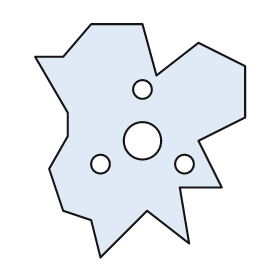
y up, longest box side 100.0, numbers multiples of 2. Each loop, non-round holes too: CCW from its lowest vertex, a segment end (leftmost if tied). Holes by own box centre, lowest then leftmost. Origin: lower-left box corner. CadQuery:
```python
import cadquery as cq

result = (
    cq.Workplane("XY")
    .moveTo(28.0, 0.0)
    .lineTo(48.0, 20.0)
    .lineTo(66.0, 6.0)
    .lineTo(62.0, 30.0)
    .lineTo(80.0, 30.0)
    .lineTo(70.0, 50.0)
    .lineTo(90.0, 60.0)
    .lineTo(90.0, 82.0)
    .lineTo(70.0, 92.0)
    .lineTo(52.0, 78.0)
    .lineTo(46.0, 100.0)
    .lineTo(24.0, 100.0)
    .lineTo(12.0, 86.0)
    .lineTo(0.0, 86.0)
    .lineTo(14.0, 62.0)
    .lineTo(14.0, 52.0)
    .lineTo(6.0, 38.0)
    .lineTo(12.0, 20.0)
    .lineTo(24.0, 16.0)
    .close()
    .moveTo(28.0, 40.0)
    .circle(4.0)
    .moveTo(64.0, 40.0)
    .circle(4.0)
    .moveTo(46.0, 50.0)
    .circle(8.0)
    .moveTo(46.0, 72.0)
    .circle(4.0)
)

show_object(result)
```